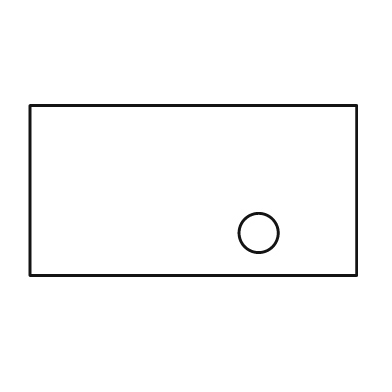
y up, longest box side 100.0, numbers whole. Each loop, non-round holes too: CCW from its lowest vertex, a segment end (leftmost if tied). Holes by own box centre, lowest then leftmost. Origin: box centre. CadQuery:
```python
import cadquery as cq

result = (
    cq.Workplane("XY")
    .moveTo(-50.0, -26.0)
    .lineTo(50.0, -26.0)
    .lineTo(50.0, 26.0)
    .lineTo(-50.0, 26.0)
    .close()
    .moveTo(20.0, -13.0)
    .circle(6.0)
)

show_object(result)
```